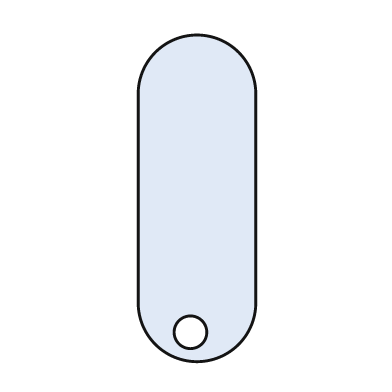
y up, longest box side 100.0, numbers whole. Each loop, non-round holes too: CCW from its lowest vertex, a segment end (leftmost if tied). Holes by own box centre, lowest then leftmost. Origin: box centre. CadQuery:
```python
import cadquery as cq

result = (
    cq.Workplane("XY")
    .moveTo(-18.0, -32.0)
    .threePointArc((0.0, -50.0), (18.0, -32.0))
    .lineTo(18.0, 32.0)
    .threePointArc((0.0, 50.0), (-18.0, 32.0))
    .close()
    .moveTo(-2.0, -41.0)
    .circle(5.0)
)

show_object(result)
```